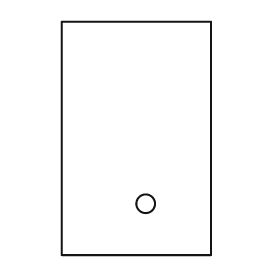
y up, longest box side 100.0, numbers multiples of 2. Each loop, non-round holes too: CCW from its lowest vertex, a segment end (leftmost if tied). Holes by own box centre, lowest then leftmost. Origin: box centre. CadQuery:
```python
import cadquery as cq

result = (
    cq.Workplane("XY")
    .moveTo(-32.0, -50.0)
    .lineTo(32.0, -50.0)
    .lineTo(32.0, 50.0)
    .lineTo(-32.0, 50.0)
    .close()
    .moveTo(4.0, -28.0)
    .circle(4.0)
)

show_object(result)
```